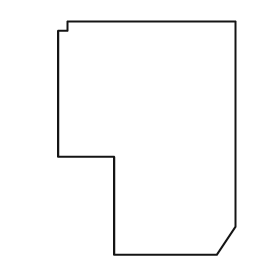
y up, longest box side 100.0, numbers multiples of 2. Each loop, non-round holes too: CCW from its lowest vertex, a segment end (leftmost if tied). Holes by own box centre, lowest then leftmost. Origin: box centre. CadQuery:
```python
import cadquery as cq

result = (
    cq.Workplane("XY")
    .moveTo(-14.0, -50.0)
    .lineTo(30.0, -50.0)
    .lineTo(38.0, -38.0)
    .lineTo(38.0, 50.0)
    .lineTo(-34.0, 50.0)
    .lineTo(-34.0, 46.0)
    .lineTo(-38.0, 46.0)
    .lineTo(-38.0, -8.0)
    .lineTo(-14.0, -8.0)
    .close()
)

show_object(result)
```